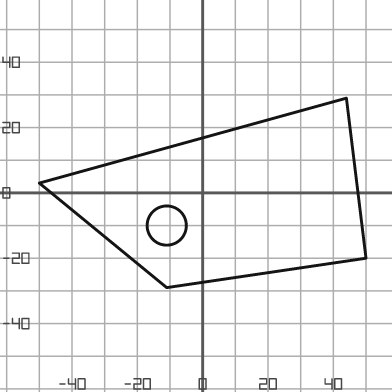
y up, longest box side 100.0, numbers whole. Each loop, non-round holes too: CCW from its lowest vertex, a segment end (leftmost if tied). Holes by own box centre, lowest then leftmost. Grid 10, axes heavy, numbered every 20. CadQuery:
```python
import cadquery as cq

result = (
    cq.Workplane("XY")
    .moveTo(-11.0, -29.0)
    .lineTo(50.0, -20.0)
    .lineTo(44.0, 29.0)
    .lineTo(-50.0, 3.0)
    .close()
    .moveTo(-11.0, -10.0)
    .circle(6.0)
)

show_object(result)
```